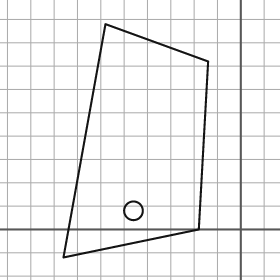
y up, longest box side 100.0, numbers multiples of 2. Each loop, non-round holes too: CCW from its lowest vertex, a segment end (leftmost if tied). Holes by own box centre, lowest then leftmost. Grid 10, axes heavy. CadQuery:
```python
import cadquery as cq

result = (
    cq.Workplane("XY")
    .moveTo(-76.0, -12.0)
    .lineTo(-18.0, 0.0)
    .lineTo(-14.0, 72.0)
    .lineTo(-58.0, 88.0)
    .close()
    .moveTo(-46.0, 8.0)
    .circle(4.0)
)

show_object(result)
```